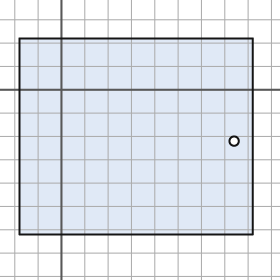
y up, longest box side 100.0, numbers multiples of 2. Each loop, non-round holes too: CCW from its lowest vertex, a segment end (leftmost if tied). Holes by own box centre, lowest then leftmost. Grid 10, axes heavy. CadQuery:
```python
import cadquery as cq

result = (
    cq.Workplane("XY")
    .moveTo(-18.0, -62.0)
    .lineTo(82.0, -62.0)
    .lineTo(82.0, 22.0)
    .lineTo(-18.0, 22.0)
    .close()
    .moveTo(74.0, -22.0)
    .circle(2.0)
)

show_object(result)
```